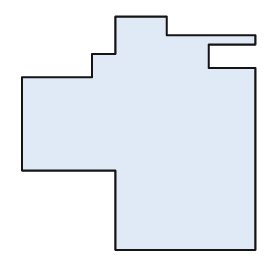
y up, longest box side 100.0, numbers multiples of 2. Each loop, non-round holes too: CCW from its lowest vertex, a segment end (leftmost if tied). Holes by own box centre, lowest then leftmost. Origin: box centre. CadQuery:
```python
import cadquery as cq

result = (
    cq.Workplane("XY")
    .moveTo(-10.0, -50.0)
    .lineTo(50.0, -50.0)
    .lineTo(50.0, 28.0)
    .lineTo(30.0, 28.0)
    .lineTo(30.0, 38.0)
    .lineTo(50.0, 38.0)
    .lineTo(50.0, 42.0)
    .lineTo(12.0, 42.0)
    .lineTo(12.0, 50.0)
    .lineTo(-10.0, 50.0)
    .lineTo(-10.0, 34.0)
    .lineTo(-20.0, 34.0)
    .lineTo(-20.0, 24.0)
    .lineTo(-50.0, 24.0)
    .lineTo(-50.0, -16.0)
    .lineTo(-10.0, -16.0)
    .close()
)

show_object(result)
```